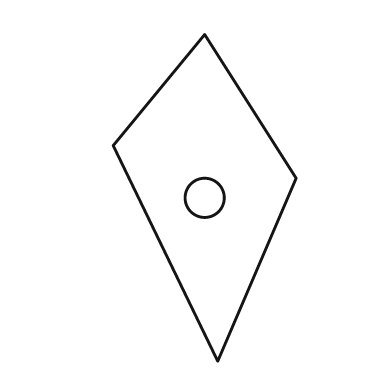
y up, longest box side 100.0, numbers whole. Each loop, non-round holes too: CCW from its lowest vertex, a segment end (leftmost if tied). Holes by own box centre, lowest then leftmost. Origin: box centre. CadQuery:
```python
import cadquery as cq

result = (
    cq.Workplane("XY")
    .moveTo(4.0, -50.0)
    .lineTo(28.0, 6.0)
    .lineTo(0.0, 50.0)
    .lineTo(-28.0, 16.0)
    .close()
    .moveTo(0.0, 0.0)
    .circle(6.0)
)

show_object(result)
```